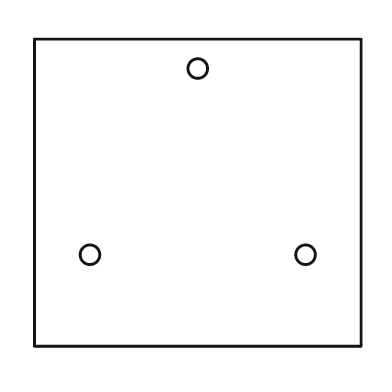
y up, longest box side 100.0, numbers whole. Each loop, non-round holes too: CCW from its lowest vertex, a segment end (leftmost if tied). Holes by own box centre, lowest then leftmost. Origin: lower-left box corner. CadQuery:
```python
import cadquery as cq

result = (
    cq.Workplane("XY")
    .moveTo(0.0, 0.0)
    .lineTo(100.0, 0.0)
    .lineTo(100.0, 94.0)
    .lineTo(0.0, 94.0)
    .close()
    .moveTo(17.0, 28.0)
    .circle(3.0)
    .moveTo(83.0, 28.0)
    .circle(3.0)
    .moveTo(50.0, 85.0)
    .circle(3.0)
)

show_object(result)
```